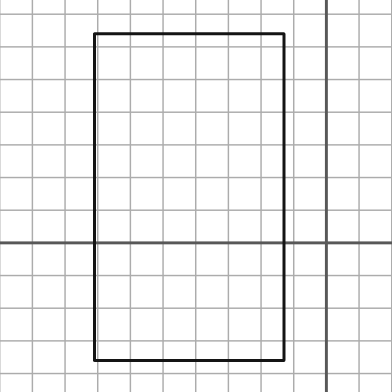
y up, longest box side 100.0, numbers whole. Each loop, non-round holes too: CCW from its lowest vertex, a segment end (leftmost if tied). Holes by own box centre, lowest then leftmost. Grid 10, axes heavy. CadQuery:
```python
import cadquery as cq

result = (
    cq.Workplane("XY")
    .moveTo(-71.0, -36.0)
    .lineTo(-13.0, -36.0)
    .lineTo(-13.0, 64.0)
    .lineTo(-71.0, 64.0)
    .close()
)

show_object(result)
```